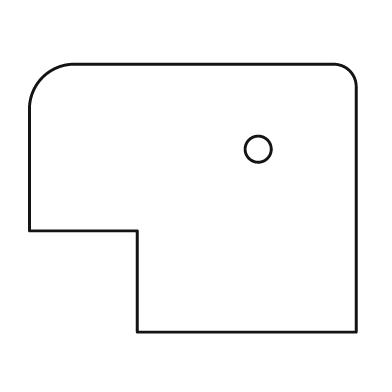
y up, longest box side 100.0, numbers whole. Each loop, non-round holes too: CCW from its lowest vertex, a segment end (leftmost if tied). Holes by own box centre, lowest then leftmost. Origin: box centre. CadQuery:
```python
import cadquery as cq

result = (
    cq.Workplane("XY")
    .moveTo(-17.0, -41.0)
    .lineTo(50.0, -41.0)
    .lineTo(50.0, 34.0)
    .threePointArc((48.0, 39.0), (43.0, 41.0))
    .lineTo(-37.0, 41.0)
    .threePointArc((-46.0, 37.0), (-50.0, 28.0))
    .lineTo(-50.0, -10.0)
    .lineTo(-17.0, -10.0)
    .close()
    .moveTo(20.0, 15.0)
    .circle(4.0)
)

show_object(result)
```